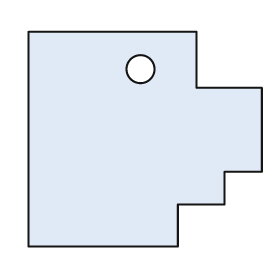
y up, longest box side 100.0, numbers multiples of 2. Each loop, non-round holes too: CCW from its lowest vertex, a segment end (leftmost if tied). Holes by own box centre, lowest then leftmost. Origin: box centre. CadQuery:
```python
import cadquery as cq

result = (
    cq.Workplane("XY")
    .moveTo(-50.0, -46.0)
    .lineTo(14.0, -46.0)
    .lineTo(14.0, -28.0)
    .lineTo(34.0, -28.0)
    .lineTo(34.0, -14.0)
    .lineTo(50.0, -14.0)
    .lineTo(50.0, 22.0)
    .lineTo(22.0, 22.0)
    .lineTo(22.0, 46.0)
    .lineTo(-50.0, 46.0)
    .close()
    .moveTo(-2.0, 30.0)
    .circle(6.0)
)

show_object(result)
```